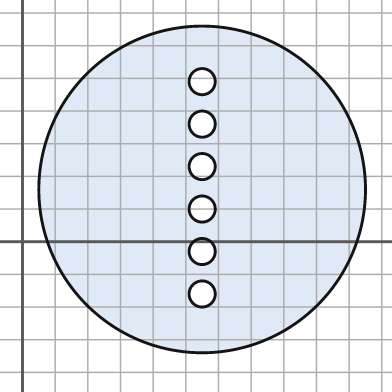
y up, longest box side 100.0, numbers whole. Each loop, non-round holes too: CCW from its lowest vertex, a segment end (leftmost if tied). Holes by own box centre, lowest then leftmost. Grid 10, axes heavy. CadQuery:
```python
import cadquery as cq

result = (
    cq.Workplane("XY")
    .moveTo(55.0, 16.0)
    .circle(50.0)
    .moveTo(55.0, -16.0)
    .circle(4.0)
    .moveTo(55.0, -3.0)
    .circle(4.0)
    .moveTo(55.0, 10.0)
    .circle(4.0)
    .moveTo(55.0, 23.0)
    .circle(4.0)
    .moveTo(55.0, 36.0)
    .circle(4.0)
    .moveTo(55.0, 49.0)
    .circle(4.0)
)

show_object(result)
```